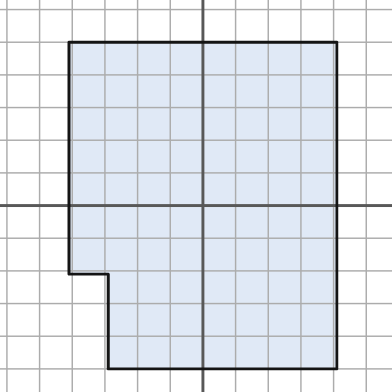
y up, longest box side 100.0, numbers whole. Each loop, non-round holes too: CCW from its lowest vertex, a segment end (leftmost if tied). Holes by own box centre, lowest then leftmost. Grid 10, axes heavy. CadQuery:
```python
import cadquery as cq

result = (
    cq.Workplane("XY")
    .moveTo(-29.0, -50.0)
    .lineTo(41.0, -50.0)
    .lineTo(41.0, 50.0)
    .lineTo(-41.0, 50.0)
    .lineTo(-41.0, -21.0)
    .lineTo(-29.0, -21.0)
    .close()
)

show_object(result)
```